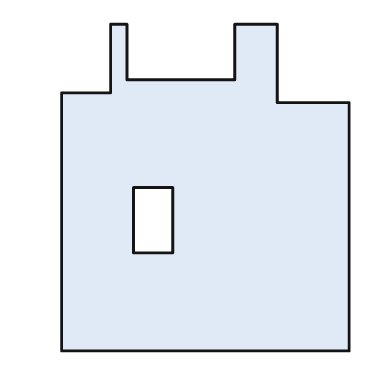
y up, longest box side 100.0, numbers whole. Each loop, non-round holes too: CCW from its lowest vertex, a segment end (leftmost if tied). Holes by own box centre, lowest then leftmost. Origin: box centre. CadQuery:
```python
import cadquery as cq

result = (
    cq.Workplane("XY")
    .moveTo(-44.0, -50.0)
    .lineTo(44.0, -50.0)
    .lineTo(44.0, 26.0)
    .lineTo(22.0, 26.0)
    .lineTo(22.0, 50.0)
    .lineTo(9.0, 50.0)
    .lineTo(9.0, 33.0)
    .lineTo(-24.0, 33.0)
    .lineTo(-24.0, 50.0)
    .lineTo(-29.0, 50.0)
    .lineTo(-29.0, 29.0)
    .lineTo(-44.0, 29.0)
    .close()
    .moveTo(-22.0, -20.0)
    .lineTo(-10.0, -20.0)
    .lineTo(-10.0, 0.0)
    .lineTo(-22.0, 0.0)
    .close()
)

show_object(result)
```